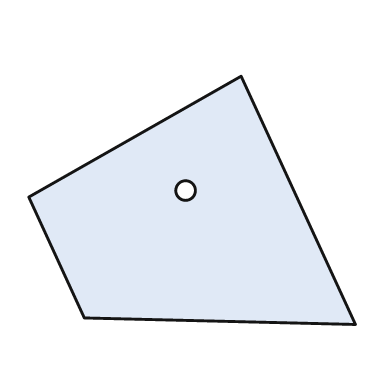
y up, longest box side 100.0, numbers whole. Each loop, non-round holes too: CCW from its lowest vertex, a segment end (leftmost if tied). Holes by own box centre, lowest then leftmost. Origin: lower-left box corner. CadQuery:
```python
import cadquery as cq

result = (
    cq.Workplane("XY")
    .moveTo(100.0, 0.0)
    .lineTo(65.0, 76.0)
    .lineTo(0.0, 39.0)
    .lineTo(17.0, 2.0)
    .close()
    .moveTo(48.0, 41.0)
    .circle(3.0)
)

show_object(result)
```